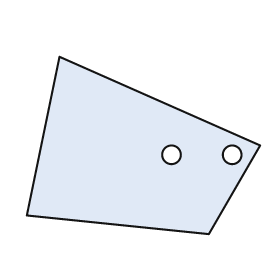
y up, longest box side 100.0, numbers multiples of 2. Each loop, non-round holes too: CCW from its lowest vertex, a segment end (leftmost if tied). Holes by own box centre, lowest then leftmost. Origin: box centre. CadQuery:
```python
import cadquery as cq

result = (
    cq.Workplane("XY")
    .moveTo(28.0, -38.0)
    .lineTo(50.0, 0.0)
    .lineTo(-36.0, 38.0)
    .lineTo(-50.0, -30.0)
    .close()
    .moveTo(12.0, -4.0)
    .circle(4.0)
    .moveTo(38.0, -4.0)
    .circle(4.0)
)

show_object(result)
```